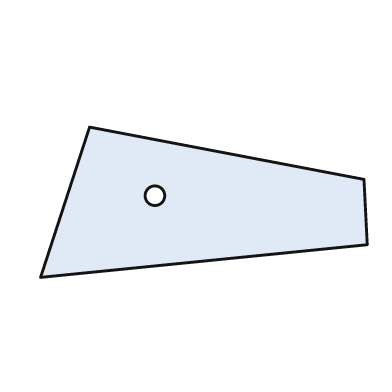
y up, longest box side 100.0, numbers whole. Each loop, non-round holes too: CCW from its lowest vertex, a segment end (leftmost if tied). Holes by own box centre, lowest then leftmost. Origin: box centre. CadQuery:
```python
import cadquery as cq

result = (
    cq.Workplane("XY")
    .moveTo(-50.0, -23.0)
    .lineTo(50.0, -13.0)
    .lineTo(49.0, 7.0)
    .lineTo(-35.0, 23.0)
    .close()
    .moveTo(-15.0, 2.0)
    .circle(3.0)
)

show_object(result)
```